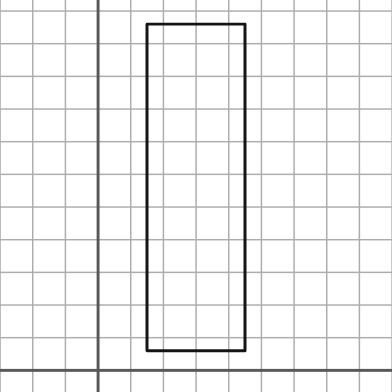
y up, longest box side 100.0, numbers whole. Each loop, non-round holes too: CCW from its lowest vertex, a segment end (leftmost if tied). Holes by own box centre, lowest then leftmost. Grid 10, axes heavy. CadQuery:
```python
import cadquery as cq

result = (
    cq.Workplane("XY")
    .moveTo(15.0, 6.0)
    .lineTo(45.0, 6.0)
    .lineTo(45.0, 106.0)
    .lineTo(15.0, 106.0)
    .close()
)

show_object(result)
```